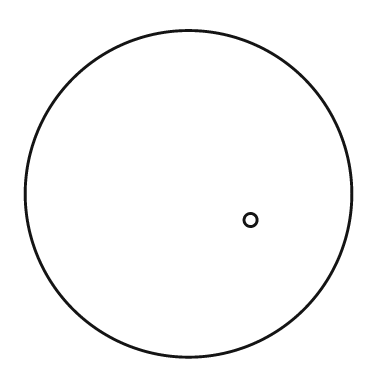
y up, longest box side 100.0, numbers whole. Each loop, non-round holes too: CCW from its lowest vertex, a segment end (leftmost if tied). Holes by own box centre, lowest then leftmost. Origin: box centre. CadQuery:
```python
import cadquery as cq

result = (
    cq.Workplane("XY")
    .moveTo(0.0, 0.0)
    .circle(50.0)
    .moveTo(19.0, -8.0)
    .circle(2.0)
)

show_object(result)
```